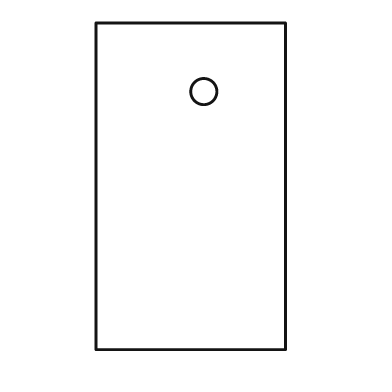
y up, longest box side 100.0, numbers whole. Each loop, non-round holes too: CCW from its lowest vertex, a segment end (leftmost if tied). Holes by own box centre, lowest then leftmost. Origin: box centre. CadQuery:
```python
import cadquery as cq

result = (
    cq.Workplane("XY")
    .moveTo(-29.0, -50.0)
    .lineTo(29.0, -50.0)
    .lineTo(29.0, 50.0)
    .lineTo(-29.0, 50.0)
    .close()
    .moveTo(4.0, 29.0)
    .circle(4.0)
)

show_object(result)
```